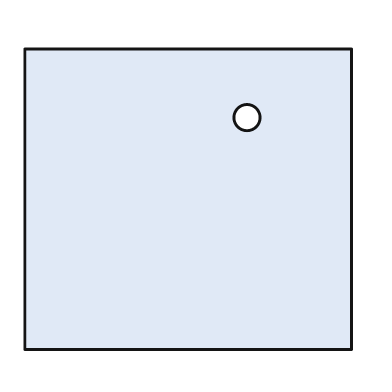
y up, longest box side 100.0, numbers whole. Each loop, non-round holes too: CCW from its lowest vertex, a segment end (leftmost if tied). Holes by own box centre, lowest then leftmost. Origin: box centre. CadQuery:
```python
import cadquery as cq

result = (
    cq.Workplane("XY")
    .moveTo(-50.0, -46.0)
    .lineTo(50.0, -46.0)
    .lineTo(50.0, 46.0)
    .lineTo(-50.0, 46.0)
    .close()
    .moveTo(18.0, 25.0)
    .circle(4.0)
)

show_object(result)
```